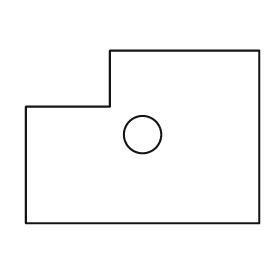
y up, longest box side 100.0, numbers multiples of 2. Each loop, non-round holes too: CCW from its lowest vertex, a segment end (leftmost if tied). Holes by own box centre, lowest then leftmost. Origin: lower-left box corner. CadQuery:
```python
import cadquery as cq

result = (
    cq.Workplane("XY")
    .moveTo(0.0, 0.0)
    .lineTo(100.0, 0.0)
    .lineTo(100.0, 74.0)
    .lineTo(36.0, 74.0)
    .lineTo(36.0, 50.0)
    .lineTo(0.0, 50.0)
    .close()
    .moveTo(50.0, 38.0)
    .circle(8.0)
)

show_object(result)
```